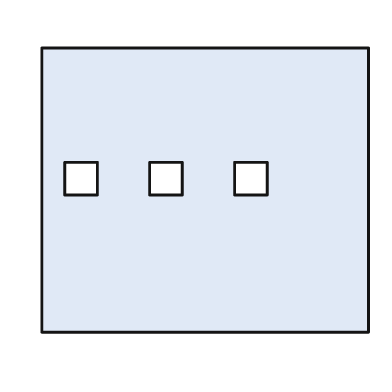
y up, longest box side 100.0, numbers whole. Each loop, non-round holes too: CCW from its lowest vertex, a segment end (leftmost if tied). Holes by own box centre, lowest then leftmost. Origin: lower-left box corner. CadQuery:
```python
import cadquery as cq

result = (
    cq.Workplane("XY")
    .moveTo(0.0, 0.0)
    .lineTo(100.0, 0.0)
    .lineTo(100.0, 87.0)
    .lineTo(0.0, 87.0)
    .close()
    .moveTo(7.0, 42.0)
    .lineTo(17.0, 42.0)
    .lineTo(17.0, 52.0)
    .lineTo(7.0, 52.0)
    .close()
    .moveTo(33.0, 42.0)
    .lineTo(43.0, 42.0)
    .lineTo(43.0, 52.0)
    .lineTo(33.0, 52.0)
    .close()
    .moveTo(59.0, 42.0)
    .lineTo(69.0, 42.0)
    .lineTo(69.0, 52.0)
    .lineTo(59.0, 52.0)
    .close()
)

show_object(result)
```